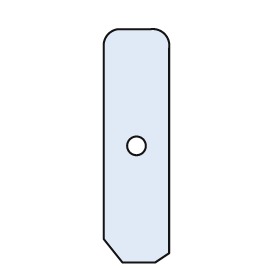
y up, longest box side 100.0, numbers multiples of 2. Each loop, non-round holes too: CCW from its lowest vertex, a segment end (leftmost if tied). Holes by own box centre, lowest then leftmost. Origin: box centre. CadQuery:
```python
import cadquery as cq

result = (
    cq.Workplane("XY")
    .moveTo(-6.0, -50.0)
    .lineTo(8.0, -50.0)
    .lineTo(14.0, -46.0)
    .lineTo(14.0, 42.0)
    .threePointArc((12.0, 48.0), (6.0, 50.0))
    .lineTo(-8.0, 50.0)
    .threePointArc((-12.0, 48.0), (-14.0, 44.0))
    .lineTo(-14.0, -40.0)
    .close()
    .moveTo(0.0, 0.0)
    .circle(4.0)
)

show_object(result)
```